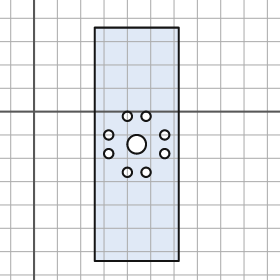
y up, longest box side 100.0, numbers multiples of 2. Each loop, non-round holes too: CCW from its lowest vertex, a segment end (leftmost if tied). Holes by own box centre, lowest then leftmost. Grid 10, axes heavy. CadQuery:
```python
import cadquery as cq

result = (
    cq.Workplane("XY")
    .moveTo(26.0, -64.0)
    .lineTo(62.0, -64.0)
    .lineTo(62.0, 36.0)
    .lineTo(26.0, 36.0)
    .close()
    .moveTo(40.0, -26.0)
    .circle(2.0)
    .moveTo(48.0, -26.0)
    .circle(2.0)
    .moveTo(32.0, -18.0)
    .circle(2.0)
    .moveTo(56.0, -18.0)
    .circle(2.0)
    .moveTo(44.0, -14.0)
    .circle(4.0)
    .moveTo(32.0, -10.0)
    .circle(2.0)
    .moveTo(56.0, -10.0)
    .circle(2.0)
    .moveTo(40.0, -2.0)
    .circle(2.0)
    .moveTo(48.0, -2.0)
    .circle(2.0)
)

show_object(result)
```